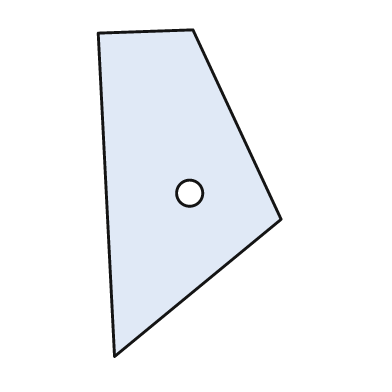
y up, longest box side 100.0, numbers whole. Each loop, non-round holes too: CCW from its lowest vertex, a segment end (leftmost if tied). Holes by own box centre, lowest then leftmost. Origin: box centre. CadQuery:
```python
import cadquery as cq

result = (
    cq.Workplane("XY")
    .moveTo(-23.0, -50.0)
    .lineTo(28.0, -8.0)
    .lineTo(1.0, 50.0)
    .lineTo(-28.0, 49.0)
    .close()
    .moveTo(0.0, 0.0)
    .circle(4.0)
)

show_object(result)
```